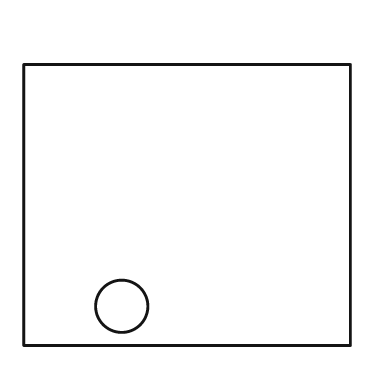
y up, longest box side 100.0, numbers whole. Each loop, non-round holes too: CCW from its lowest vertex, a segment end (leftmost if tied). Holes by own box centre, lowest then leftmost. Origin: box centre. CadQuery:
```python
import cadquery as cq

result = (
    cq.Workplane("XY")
    .moveTo(-50.0, -43.0)
    .lineTo(50.0, -43.0)
    .lineTo(50.0, 43.0)
    .lineTo(-50.0, 43.0)
    .close()
    .moveTo(-20.0, -31.0)
    .circle(8.0)
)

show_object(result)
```